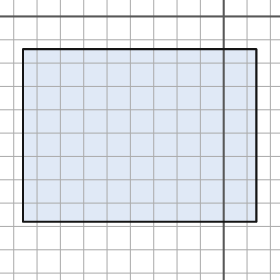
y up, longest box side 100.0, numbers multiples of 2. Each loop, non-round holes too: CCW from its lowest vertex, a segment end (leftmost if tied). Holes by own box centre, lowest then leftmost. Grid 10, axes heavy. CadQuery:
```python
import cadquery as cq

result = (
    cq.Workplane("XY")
    .moveTo(-86.0, -88.0)
    .lineTo(14.0, -88.0)
    .lineTo(14.0, -14.0)
    .lineTo(-86.0, -14.0)
    .close()
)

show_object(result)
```